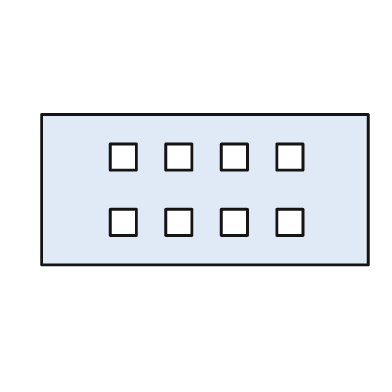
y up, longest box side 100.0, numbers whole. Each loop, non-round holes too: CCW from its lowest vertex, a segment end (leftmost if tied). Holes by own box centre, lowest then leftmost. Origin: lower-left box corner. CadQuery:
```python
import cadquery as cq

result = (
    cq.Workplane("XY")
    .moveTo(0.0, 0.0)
    .lineTo(100.0, 0.0)
    .lineTo(100.0, 46.0)
    .lineTo(0.0, 46.0)
    .close()
    .moveTo(21.0, 9.0)
    .lineTo(29.0, 9.0)
    .lineTo(29.0, 17.0)
    .lineTo(21.0, 17.0)
    .close()
    .moveTo(38.0, 9.0)
    .lineTo(46.0, 9.0)
    .lineTo(46.0, 17.0)
    .lineTo(38.0, 17.0)
    .close()
    .moveTo(55.0, 9.0)
    .lineTo(63.0, 9.0)
    .lineTo(63.0, 17.0)
    .lineTo(55.0, 17.0)
    .close()
    .moveTo(72.0, 9.0)
    .lineTo(80.0, 9.0)
    .lineTo(80.0, 17.0)
    .lineTo(72.0, 17.0)
    .close()
    .moveTo(21.0, 29.0)
    .lineTo(29.0, 29.0)
    .lineTo(29.0, 37.0)
    .lineTo(21.0, 37.0)
    .close()
    .moveTo(38.0, 29.0)
    .lineTo(46.0, 29.0)
    .lineTo(46.0, 37.0)
    .lineTo(38.0, 37.0)
    .close()
    .moveTo(55.0, 29.0)
    .lineTo(63.0, 29.0)
    .lineTo(63.0, 37.0)
    .lineTo(55.0, 37.0)
    .close()
    .moveTo(72.0, 29.0)
    .lineTo(80.0, 29.0)
    .lineTo(80.0, 37.0)
    .lineTo(72.0, 37.0)
    .close()
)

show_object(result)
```